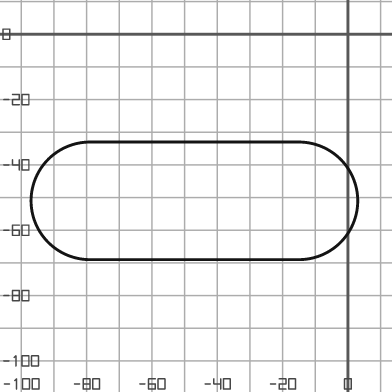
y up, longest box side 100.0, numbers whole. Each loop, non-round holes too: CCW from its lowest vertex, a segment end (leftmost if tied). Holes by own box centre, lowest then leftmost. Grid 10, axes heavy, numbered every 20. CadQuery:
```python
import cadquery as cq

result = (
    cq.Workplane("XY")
    .moveTo(-79.0, -69.0)
    .lineTo(-15.0, -69.0)
    .threePointArc((3.0, -51.0), (-15.0, -33.0))
    .lineTo(-79.0, -33.0)
    .threePointArc((-97.0, -51.0), (-79.0, -69.0))
    .close()
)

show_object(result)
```